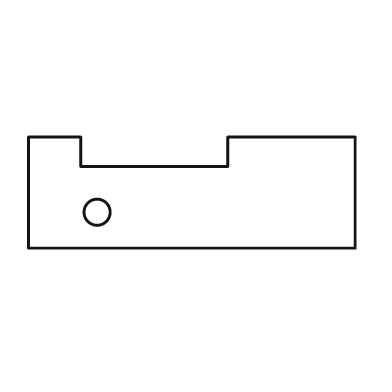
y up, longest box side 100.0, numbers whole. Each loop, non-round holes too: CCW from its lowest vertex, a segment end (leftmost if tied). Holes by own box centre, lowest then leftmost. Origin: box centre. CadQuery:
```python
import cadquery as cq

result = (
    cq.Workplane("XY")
    .moveTo(-50.0, -17.0)
    .lineTo(50.0, -17.0)
    .lineTo(50.0, 17.0)
    .lineTo(11.0, 17.0)
    .lineTo(11.0, 8.0)
    .lineTo(-34.0, 8.0)
    .lineTo(-34.0, 17.0)
    .lineTo(-50.0, 17.0)
    .close()
    .moveTo(-29.0, -6.0)
    .circle(4.0)
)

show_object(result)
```